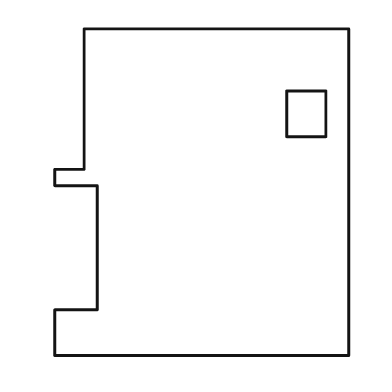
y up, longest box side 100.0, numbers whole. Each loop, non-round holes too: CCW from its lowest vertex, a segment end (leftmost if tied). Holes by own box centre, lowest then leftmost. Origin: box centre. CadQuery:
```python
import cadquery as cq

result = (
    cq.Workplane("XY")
    .moveTo(-45.0, -50.0)
    .lineTo(45.0, -50.0)
    .lineTo(45.0, 50.0)
    .lineTo(-36.0, 50.0)
    .lineTo(-36.0, 7.0)
    .lineTo(-45.0, 7.0)
    .lineTo(-45.0, 2.0)
    .lineTo(-32.0, 2.0)
    .lineTo(-32.0, -36.0)
    .lineTo(-45.0, -36.0)
    .close()
    .moveTo(26.0, 17.0)
    .lineTo(38.0, 17.0)
    .lineTo(38.0, 31.0)
    .lineTo(26.0, 31.0)
    .close()
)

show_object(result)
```